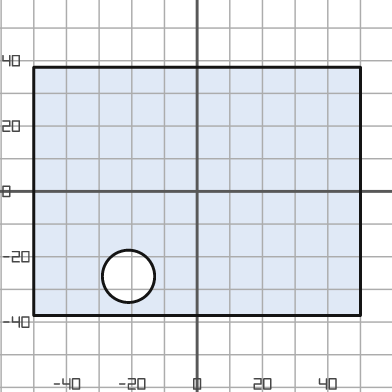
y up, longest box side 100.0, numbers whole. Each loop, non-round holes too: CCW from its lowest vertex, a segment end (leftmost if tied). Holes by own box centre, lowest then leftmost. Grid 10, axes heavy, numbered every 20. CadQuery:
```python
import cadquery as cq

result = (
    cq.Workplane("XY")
    .moveTo(-50.0, -38.0)
    .lineTo(50.0, -38.0)
    .lineTo(50.0, 38.0)
    .lineTo(-50.0, 38.0)
    .close()
    .moveTo(-21.0, -26.0)
    .circle(8.0)
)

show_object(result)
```